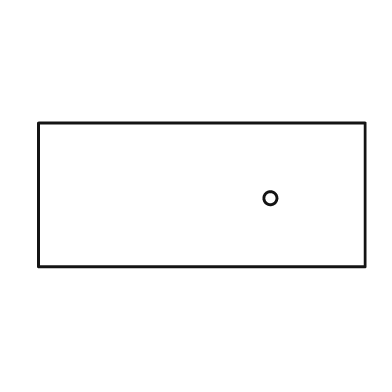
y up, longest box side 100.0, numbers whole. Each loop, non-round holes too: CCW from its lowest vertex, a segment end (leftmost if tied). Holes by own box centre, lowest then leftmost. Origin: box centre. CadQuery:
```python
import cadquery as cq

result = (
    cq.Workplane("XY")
    .moveTo(-50.0, -22.0)
    .lineTo(50.0, -22.0)
    .lineTo(50.0, 22.0)
    .lineTo(-50.0, 22.0)
    .close()
    .moveTo(21.0, -1.0)
    .circle(2.0)
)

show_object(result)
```